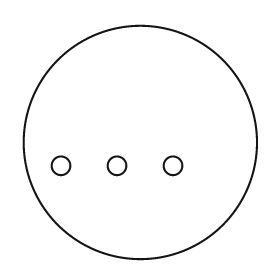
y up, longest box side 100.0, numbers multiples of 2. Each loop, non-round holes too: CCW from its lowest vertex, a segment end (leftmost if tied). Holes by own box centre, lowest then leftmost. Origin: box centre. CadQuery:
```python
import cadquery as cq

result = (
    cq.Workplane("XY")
    .moveTo(0.0, 0.0)
    .circle(50.0)
    .moveTo(-34.0, -10.0)
    .circle(4.0)
    .moveTo(-10.0, -10.0)
    .circle(4.0)
    .moveTo(14.0, -10.0)
    .circle(4.0)
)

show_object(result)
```